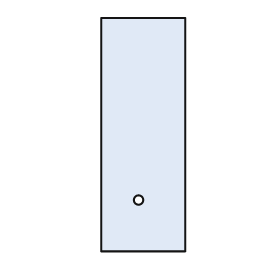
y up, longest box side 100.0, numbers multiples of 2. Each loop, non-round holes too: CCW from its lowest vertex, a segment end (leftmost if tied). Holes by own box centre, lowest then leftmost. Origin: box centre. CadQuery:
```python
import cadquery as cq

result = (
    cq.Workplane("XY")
    .moveTo(-18.0, -50.0)
    .lineTo(18.0, -50.0)
    .lineTo(18.0, 50.0)
    .lineTo(-18.0, 50.0)
    .close()
    .moveTo(-2.0, -28.0)
    .circle(2.0)
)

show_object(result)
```